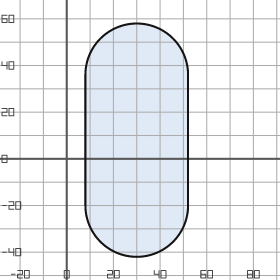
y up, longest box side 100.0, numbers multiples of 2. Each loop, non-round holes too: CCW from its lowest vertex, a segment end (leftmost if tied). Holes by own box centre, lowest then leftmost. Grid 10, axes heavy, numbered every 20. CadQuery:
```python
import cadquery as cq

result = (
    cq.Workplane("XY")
    .moveTo(8.0, -20.0)
    .threePointArc((30.0, -42.0), (52.0, -20.0))
    .lineTo(52.0, 36.0)
    .threePointArc((30.0, 58.0), (8.0, 36.0))
    .close()
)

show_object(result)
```